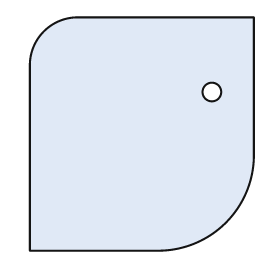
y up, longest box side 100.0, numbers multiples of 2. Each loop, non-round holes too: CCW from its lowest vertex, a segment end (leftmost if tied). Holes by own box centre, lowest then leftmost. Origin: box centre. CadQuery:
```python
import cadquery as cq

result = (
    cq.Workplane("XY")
    .moveTo(-48.0, -50.0)
    .lineTo(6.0, -50.0)
    .threePointArc((36.0, -38.0), (48.0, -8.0))
    .lineTo(48.0, 50.0)
    .lineTo(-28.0, 50.0)
    .threePointArc((-42.0, 44.0), (-48.0, 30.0))
    .close()
    .moveTo(30.0, 18.0)
    .circle(4.0)
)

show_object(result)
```